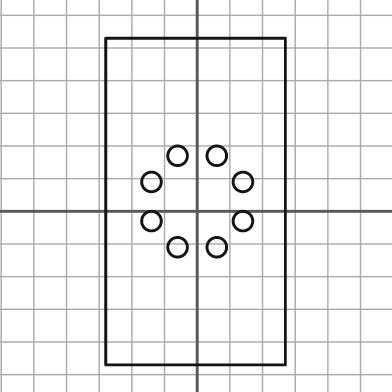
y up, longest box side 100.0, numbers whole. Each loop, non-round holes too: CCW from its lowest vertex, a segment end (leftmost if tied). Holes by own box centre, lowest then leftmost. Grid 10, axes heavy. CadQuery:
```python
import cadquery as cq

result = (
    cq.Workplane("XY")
    .moveTo(-28.0, -47.0)
    .lineTo(27.0, -47.0)
    .lineTo(27.0, 53.0)
    .lineTo(-28.0, 53.0)
    .close()
    .moveTo(-6.0, -11.0)
    .circle(3.0)
    .moveTo(6.0, -11.0)
    .circle(3.0)
    .moveTo(-14.0, -3.0)
    .circle(3.0)
    .moveTo(14.0, -3.0)
    .circle(3.0)
    .moveTo(-14.0, 9.0)
    .circle(3.0)
    .moveTo(14.0, 9.0)
    .circle(3.0)
    .moveTo(-6.0, 17.0)
    .circle(3.0)
    .moveTo(6.0, 17.0)
    .circle(3.0)
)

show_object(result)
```